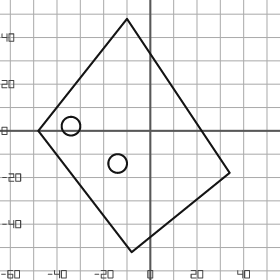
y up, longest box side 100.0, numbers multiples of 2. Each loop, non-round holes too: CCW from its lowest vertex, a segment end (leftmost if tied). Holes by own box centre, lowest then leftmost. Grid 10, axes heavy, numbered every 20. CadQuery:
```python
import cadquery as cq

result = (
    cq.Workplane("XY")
    .moveTo(-8.0, -52.0)
    .lineTo(34.0, -18.0)
    .lineTo(-10.0, 48.0)
    .lineTo(-48.0, 0.0)
    .close()
    .moveTo(-14.0, -14.0)
    .circle(4.0)
    .moveTo(-34.0, 2.0)
    .circle(4.0)
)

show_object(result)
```